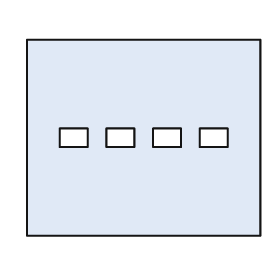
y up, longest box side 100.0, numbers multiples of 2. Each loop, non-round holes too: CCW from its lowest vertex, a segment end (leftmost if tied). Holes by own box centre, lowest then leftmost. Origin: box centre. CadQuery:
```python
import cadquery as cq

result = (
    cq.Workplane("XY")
    .moveTo(-50.0, -42.0)
    .lineTo(50.0, -42.0)
    .lineTo(50.0, 42.0)
    .lineTo(-50.0, 42.0)
    .close()
    .moveTo(-36.0, -4.0)
    .lineTo(-24.0, -4.0)
    .lineTo(-24.0, 4.0)
    .lineTo(-36.0, 4.0)
    .close()
    .moveTo(-16.0, -4.0)
    .lineTo(-4.0, -4.0)
    .lineTo(-4.0, 4.0)
    .lineTo(-16.0, 4.0)
    .close()
    .moveTo(4.0, -4.0)
    .lineTo(16.0, -4.0)
    .lineTo(16.0, 4.0)
    .lineTo(4.0, 4.0)
    .close()
    .moveTo(24.0, -4.0)
    .lineTo(36.0, -4.0)
    .lineTo(36.0, 4.0)
    .lineTo(24.0, 4.0)
    .close()
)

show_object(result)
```